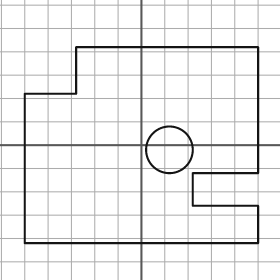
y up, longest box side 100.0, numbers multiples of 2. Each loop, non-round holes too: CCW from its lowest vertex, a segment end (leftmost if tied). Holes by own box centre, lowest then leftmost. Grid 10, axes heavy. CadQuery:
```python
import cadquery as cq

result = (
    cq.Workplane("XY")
    .moveTo(-50.0, -42.0)
    .lineTo(50.0, -42.0)
    .lineTo(50.0, -26.0)
    .lineTo(22.0, -26.0)
    .lineTo(22.0, -12.0)
    .lineTo(50.0, -12.0)
    .lineTo(50.0, 42.0)
    .lineTo(-28.0, 42.0)
    .lineTo(-28.0, 22.0)
    .lineTo(-50.0, 22.0)
    .close()
    .moveTo(12.0, -2.0)
    .circle(10.0)
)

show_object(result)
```